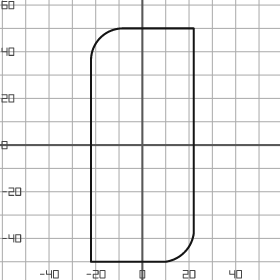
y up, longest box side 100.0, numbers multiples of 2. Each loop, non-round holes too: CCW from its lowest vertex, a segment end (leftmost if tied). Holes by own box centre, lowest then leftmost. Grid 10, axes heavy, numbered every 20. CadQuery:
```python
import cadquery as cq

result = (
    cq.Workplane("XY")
    .moveTo(-22.0, -50.0)
    .lineTo(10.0, -50.0)
    .threePointArc((18.0, -46.0), (22.0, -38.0))
    .lineTo(22.0, 50.0)
    .lineTo(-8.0, 50.0)
    .threePointArc((-18.0, 46.0), (-22.0, 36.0))
    .close()
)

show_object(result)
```